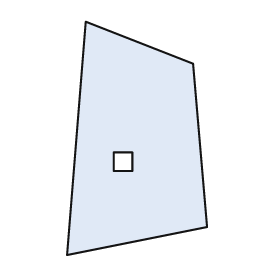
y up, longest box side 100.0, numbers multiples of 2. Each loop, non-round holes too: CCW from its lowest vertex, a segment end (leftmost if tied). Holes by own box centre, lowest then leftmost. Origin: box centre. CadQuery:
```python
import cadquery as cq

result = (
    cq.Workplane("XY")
    .moveTo(-30.0, -50.0)
    .lineTo(30.0, -38.0)
    .lineTo(24.0, 32.0)
    .lineTo(-22.0, 50.0)
    .close()
    .moveTo(-10.0, -14.0)
    .lineTo(-2.0, -14.0)
    .lineTo(-2.0, -6.0)
    .lineTo(-10.0, -6.0)
    .close()
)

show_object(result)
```